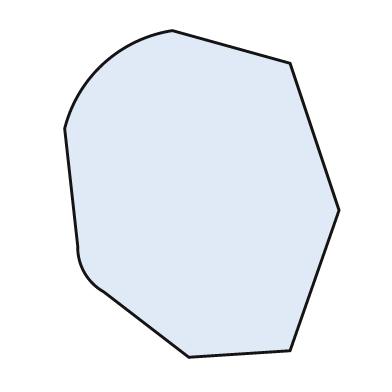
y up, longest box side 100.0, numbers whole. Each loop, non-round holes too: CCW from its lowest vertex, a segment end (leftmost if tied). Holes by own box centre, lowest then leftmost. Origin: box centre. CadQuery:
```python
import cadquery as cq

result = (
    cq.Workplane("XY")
    .moveTo(-4.0, -50.0)
    .lineTo(27.0, -48.0)
    .lineTo(42.0, -5.0)
    .lineTo(27.0, 40.0)
    .lineTo(-9.0, 50.0)
    .threePointArc((-30.0, 40.0), (-42.0, 20.0))
    .lineTo(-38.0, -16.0)
    .threePointArc((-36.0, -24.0), (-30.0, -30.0))
    .close()
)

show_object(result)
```